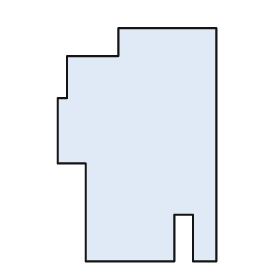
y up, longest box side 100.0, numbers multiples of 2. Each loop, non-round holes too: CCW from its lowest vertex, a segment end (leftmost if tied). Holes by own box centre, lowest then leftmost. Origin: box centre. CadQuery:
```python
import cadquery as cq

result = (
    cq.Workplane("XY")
    .moveTo(-22.0, -50.0)
    .lineTo(16.0, -50.0)
    .lineTo(16.0, -30.0)
    .lineTo(24.0, -30.0)
    .lineTo(24.0, -50.0)
    .lineTo(34.0, -50.0)
    .lineTo(34.0, 50.0)
    .lineTo(-8.0, 50.0)
    .lineTo(-8.0, 38.0)
    .lineTo(-30.0, 38.0)
    .lineTo(-30.0, 20.0)
    .lineTo(-34.0, 20.0)
    .lineTo(-34.0, -8.0)
    .lineTo(-22.0, -8.0)
    .close()
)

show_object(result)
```